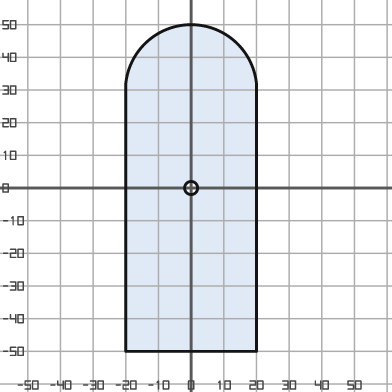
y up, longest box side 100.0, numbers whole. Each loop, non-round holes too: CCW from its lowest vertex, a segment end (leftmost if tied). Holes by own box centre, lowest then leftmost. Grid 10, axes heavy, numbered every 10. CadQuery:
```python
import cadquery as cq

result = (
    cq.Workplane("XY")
    .moveTo(-20.0, -50.0)
    .lineTo(20.0, -50.0)
    .lineTo(20.0, 32.0)
    .threePointArc((0.0, 50.0), (-20.0, 32.0))
    .close()
    .moveTo(0.0, 0.0)
    .circle(2.0)
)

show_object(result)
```